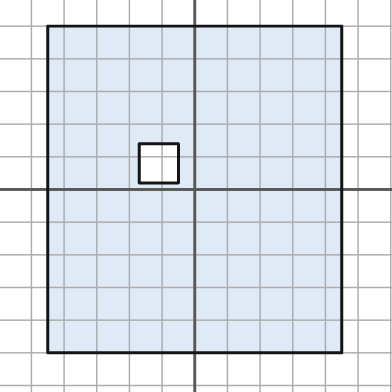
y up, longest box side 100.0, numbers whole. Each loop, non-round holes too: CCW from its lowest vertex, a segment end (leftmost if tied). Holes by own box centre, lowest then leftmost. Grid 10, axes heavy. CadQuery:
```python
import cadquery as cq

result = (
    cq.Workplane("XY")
    .moveTo(-45.0, -50.0)
    .lineTo(45.0, -50.0)
    .lineTo(45.0, 50.0)
    .lineTo(-45.0, 50.0)
    .close()
    .moveTo(-17.0, 2.0)
    .lineTo(-5.0, 2.0)
    .lineTo(-5.0, 14.0)
    .lineTo(-17.0, 14.0)
    .close()
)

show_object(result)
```